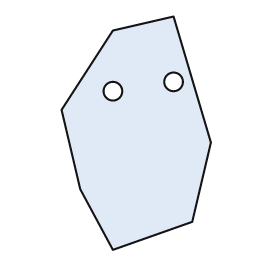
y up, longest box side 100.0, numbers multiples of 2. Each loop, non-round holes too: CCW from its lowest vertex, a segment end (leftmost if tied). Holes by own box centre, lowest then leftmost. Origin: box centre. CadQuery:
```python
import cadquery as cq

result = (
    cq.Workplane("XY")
    .moveTo(-10.0, -50.0)
    .lineTo(24.0, -38.0)
    .lineTo(32.0, -4.0)
    .lineTo(16.0, 50.0)
    .lineTo(-10.0, 44.0)
    .lineTo(-32.0, 10.0)
    .lineTo(-24.0, -24.0)
    .close()
    .moveTo(-10.0, 18.0)
    .circle(4.0)
    .moveTo(16.0, 22.0)
    .circle(4.0)
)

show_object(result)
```